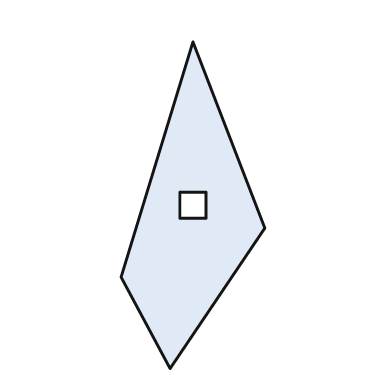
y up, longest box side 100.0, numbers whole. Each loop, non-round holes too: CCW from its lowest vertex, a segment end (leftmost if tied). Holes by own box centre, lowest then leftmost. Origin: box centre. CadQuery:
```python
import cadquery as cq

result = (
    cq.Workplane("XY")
    .moveTo(-7.0, -50.0)
    .lineTo(22.0, -7.0)
    .lineTo(0.0, 50.0)
    .lineTo(-22.0, -22.0)
    .close()
    .moveTo(-4.0, -4.0)
    .lineTo(4.0, -4.0)
    .lineTo(4.0, 4.0)
    .lineTo(-4.0, 4.0)
    .close()
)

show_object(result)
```